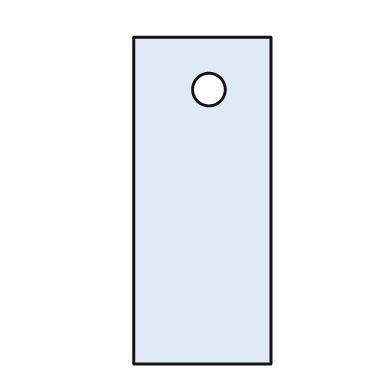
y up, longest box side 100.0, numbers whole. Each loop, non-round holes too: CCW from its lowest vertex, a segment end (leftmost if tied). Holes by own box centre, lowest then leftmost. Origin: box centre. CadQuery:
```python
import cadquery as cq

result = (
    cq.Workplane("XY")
    .moveTo(-21.0, -50.0)
    .lineTo(21.0, -50.0)
    .lineTo(21.0, 50.0)
    .lineTo(-21.0, 50.0)
    .close()
    .moveTo(2.0, 34.0)
    .circle(5.0)
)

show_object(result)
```